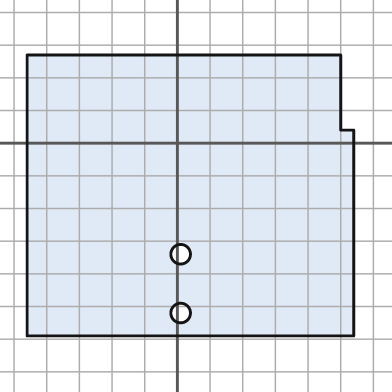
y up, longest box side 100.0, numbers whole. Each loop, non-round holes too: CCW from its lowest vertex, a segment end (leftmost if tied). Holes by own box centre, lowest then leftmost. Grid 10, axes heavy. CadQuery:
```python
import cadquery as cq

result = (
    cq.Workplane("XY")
    .moveTo(-46.0, -59.0)
    .lineTo(54.0, -59.0)
    .lineTo(54.0, 4.0)
    .lineTo(50.0, 4.0)
    .lineTo(50.0, 27.0)
    .lineTo(-46.0, 27.0)
    .close()
    .moveTo(1.0, -52.0)
    .circle(3.0)
    .moveTo(1.0, -34.0)
    .circle(3.0)
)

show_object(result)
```